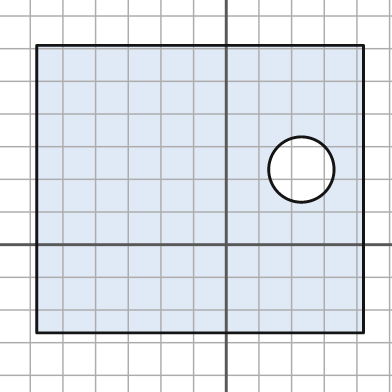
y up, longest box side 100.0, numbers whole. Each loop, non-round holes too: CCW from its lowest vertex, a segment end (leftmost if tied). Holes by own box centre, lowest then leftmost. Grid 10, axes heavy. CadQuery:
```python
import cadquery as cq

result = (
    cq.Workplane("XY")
    .moveTo(-58.0, -27.0)
    .lineTo(42.0, -27.0)
    .lineTo(42.0, 61.0)
    .lineTo(-58.0, 61.0)
    .close()
    .moveTo(23.0, 23.0)
    .circle(10.0)
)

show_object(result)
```